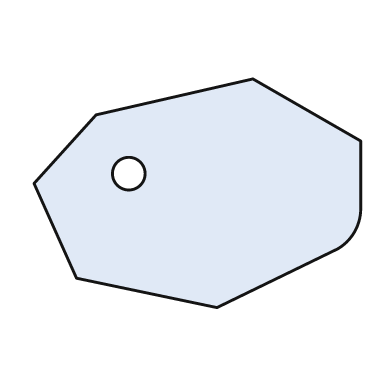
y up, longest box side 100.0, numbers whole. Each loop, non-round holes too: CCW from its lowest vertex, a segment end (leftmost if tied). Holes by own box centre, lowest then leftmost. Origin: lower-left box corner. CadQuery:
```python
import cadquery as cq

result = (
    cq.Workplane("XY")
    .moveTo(56.0, 0.0)
    .lineTo(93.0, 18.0)
    .threePointArc((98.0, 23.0), (100.0, 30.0))
    .lineTo(100.0, 51.0)
    .lineTo(67.0, 70.0)
    .lineTo(19.0, 59.0)
    .lineTo(0.0, 38.0)
    .lineTo(13.0, 9.0)
    .close()
    .moveTo(29.0, 41.0)
    .circle(5.0)
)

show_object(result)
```